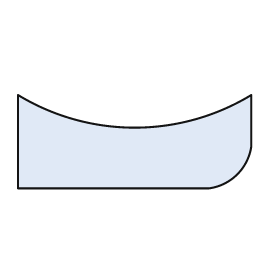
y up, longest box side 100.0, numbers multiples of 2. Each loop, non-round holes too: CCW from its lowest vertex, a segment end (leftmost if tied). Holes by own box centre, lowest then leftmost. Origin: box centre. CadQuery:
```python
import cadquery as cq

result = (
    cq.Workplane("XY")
    .moveTo(-50.0, -20.0)
    .lineTo(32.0, -20.0)
    .threePointArc((44.0, -14.0), (50.0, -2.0))
    .lineTo(50.0, 20.0)
    .threePointArc((0.0, 6.0), (-50.0, 20.0))
    .close()
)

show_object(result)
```